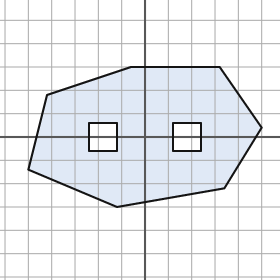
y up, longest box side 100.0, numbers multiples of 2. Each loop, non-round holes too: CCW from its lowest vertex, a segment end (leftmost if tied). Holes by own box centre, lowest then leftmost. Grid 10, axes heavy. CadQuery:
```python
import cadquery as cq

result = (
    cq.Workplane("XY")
    .moveTo(-12.0, -30.0)
    .lineTo(34.0, -22.0)
    .lineTo(50.0, 4.0)
    .lineTo(32.0, 30.0)
    .lineTo(-6.0, 30.0)
    .lineTo(-42.0, 18.0)
    .lineTo(-50.0, -14.0)
    .close()
    .moveTo(-24.0, -6.0)
    .lineTo(-12.0, -6.0)
    .lineTo(-12.0, 6.0)
    .lineTo(-24.0, 6.0)
    .close()
    .moveTo(12.0, -6.0)
    .lineTo(24.0, -6.0)
    .lineTo(24.0, 6.0)
    .lineTo(12.0, 6.0)
    .close()
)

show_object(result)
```